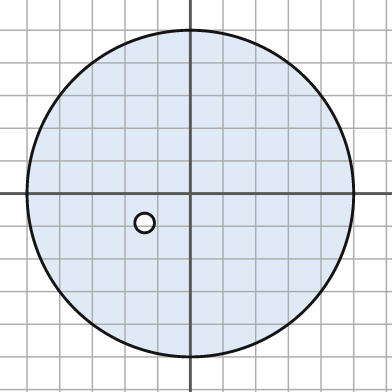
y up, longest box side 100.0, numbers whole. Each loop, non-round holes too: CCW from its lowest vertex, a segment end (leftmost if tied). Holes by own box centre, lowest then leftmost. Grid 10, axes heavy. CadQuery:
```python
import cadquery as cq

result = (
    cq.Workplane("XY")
    .moveTo(0.0, 0.0)
    .circle(50.0)
    .moveTo(-14.0, -9.0)
    .circle(3.0)
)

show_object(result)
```